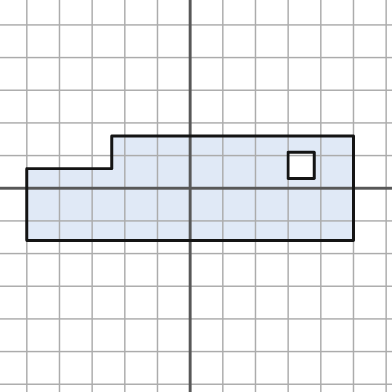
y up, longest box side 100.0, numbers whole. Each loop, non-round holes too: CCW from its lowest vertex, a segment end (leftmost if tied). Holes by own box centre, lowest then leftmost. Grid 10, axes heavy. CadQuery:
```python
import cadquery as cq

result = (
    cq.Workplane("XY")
    .moveTo(-50.0, -16.0)
    .lineTo(50.0, -16.0)
    .lineTo(50.0, 16.0)
    .lineTo(-24.0, 16.0)
    .lineTo(-24.0, 6.0)
    .lineTo(-50.0, 6.0)
    .close()
    .moveTo(30.0, 3.0)
    .lineTo(38.0, 3.0)
    .lineTo(38.0, 11.0)
    .lineTo(30.0, 11.0)
    .close()
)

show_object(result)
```